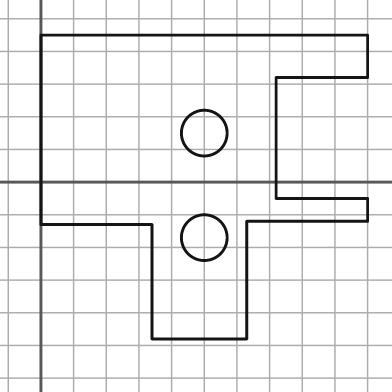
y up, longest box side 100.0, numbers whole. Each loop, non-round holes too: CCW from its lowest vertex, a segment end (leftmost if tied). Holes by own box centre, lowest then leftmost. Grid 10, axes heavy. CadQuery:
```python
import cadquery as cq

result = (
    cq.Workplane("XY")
    .moveTo(34.0, -48.0)
    .lineTo(63.0, -48.0)
    .lineTo(63.0, -12.0)
    .lineTo(100.0, -12.0)
    .lineTo(100.0, -5.0)
    .lineTo(72.0, -5.0)
    .lineTo(72.0, 32.0)
    .lineTo(100.0, 32.0)
    .lineTo(100.0, 45.0)
    .lineTo(0.0, 45.0)
    .lineTo(0.0, -13.0)
    .lineTo(34.0, -13.0)
    .close()
    .moveTo(50.0, -17.0)
    .circle(7.0)
    .moveTo(50.0, 15.0)
    .circle(7.0)
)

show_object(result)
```